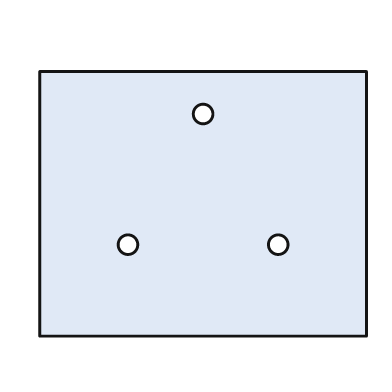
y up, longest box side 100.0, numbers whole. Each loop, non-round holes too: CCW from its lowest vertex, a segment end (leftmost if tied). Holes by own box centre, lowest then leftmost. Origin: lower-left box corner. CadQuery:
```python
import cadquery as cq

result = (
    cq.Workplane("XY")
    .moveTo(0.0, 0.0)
    .lineTo(100.0, 0.0)
    .lineTo(100.0, 81.0)
    .lineTo(0.0, 81.0)
    .close()
    .moveTo(27.0, 28.0)
    .circle(3.0)
    .moveTo(73.0, 28.0)
    .circle(3.0)
    .moveTo(50.0, 68.0)
    .circle(3.0)
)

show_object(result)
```